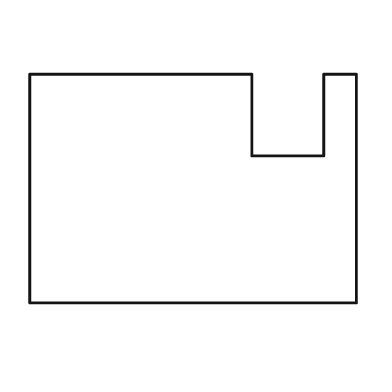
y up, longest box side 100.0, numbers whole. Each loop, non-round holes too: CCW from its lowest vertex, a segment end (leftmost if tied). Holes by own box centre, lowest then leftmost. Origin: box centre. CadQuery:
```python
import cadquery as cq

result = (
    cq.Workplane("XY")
    .moveTo(-50.0, -35.0)
    .lineTo(50.0, -35.0)
    .lineTo(50.0, 35.0)
    .lineTo(40.0, 35.0)
    .lineTo(40.0, 10.0)
    .lineTo(18.0, 10.0)
    .lineTo(18.0, 35.0)
    .lineTo(-50.0, 35.0)
    .close()
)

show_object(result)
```